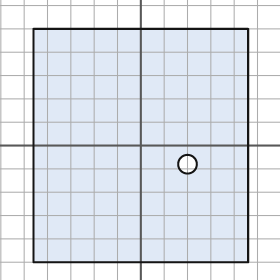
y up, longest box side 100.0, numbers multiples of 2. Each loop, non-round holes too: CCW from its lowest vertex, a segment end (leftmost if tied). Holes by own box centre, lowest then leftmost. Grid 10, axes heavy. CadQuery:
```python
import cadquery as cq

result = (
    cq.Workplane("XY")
    .moveTo(-46.0, -50.0)
    .lineTo(46.0, -50.0)
    .lineTo(46.0, 50.0)
    .lineTo(-46.0, 50.0)
    .close()
    .moveTo(20.0, -8.0)
    .circle(4.0)
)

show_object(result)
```